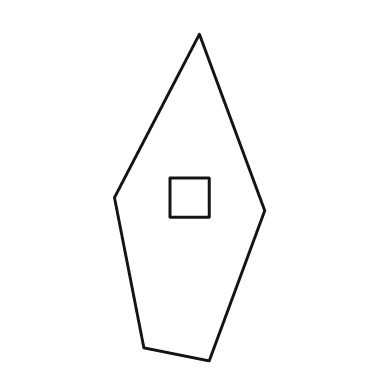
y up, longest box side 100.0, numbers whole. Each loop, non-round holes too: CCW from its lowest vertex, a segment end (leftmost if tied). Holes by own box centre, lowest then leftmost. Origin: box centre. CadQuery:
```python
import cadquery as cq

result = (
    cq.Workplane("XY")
    .moveTo(6.0, -50.0)
    .lineTo(23.0, -4.0)
    .lineTo(3.0, 50.0)
    .lineTo(-23.0, 0.0)
    .lineTo(-14.0, -46.0)
    .close()
    .moveTo(-6.0, -6.0)
    .lineTo(6.0, -6.0)
    .lineTo(6.0, 6.0)
    .lineTo(-6.0, 6.0)
    .close()
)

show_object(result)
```